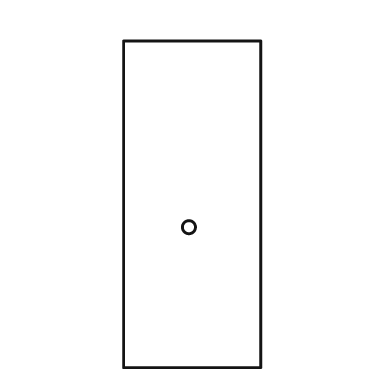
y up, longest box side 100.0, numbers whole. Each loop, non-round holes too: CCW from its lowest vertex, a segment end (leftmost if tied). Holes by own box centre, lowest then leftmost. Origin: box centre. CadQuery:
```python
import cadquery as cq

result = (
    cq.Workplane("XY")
    .moveTo(-21.0, -50.0)
    .lineTo(21.0, -50.0)
    .lineTo(21.0, 50.0)
    .lineTo(-21.0, 50.0)
    .close()
    .moveTo(-1.0, -7.0)
    .circle(2.0)
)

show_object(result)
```